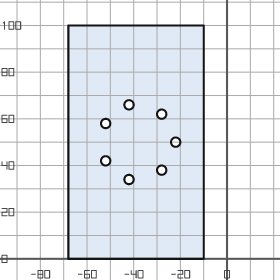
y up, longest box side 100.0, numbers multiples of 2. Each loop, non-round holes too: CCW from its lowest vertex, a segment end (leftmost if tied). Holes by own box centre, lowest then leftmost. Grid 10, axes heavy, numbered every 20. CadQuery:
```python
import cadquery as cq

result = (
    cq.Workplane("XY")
    .moveTo(-68.0, 0.0)
    .lineTo(-10.0, 0.0)
    .lineTo(-10.0, 100.0)
    .lineTo(-68.0, 100.0)
    .close()
    .moveTo(-42.0, 34.0)
    .circle(2.0)
    .moveTo(-28.0, 38.0)
    .circle(2.0)
    .moveTo(-52.0, 42.0)
    .circle(2.0)
    .moveTo(-22.0, 50.0)
    .circle(2.0)
    .moveTo(-52.0, 58.0)
    .circle(2.0)
    .moveTo(-28.0, 62.0)
    .circle(2.0)
    .moveTo(-42.0, 66.0)
    .circle(2.0)
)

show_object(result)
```